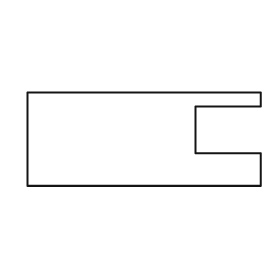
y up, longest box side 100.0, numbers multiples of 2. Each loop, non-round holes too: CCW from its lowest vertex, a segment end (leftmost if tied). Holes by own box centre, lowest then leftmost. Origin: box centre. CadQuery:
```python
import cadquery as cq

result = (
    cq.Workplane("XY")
    .moveTo(-50.0, -20.0)
    .lineTo(50.0, -20.0)
    .lineTo(50.0, -6.0)
    .lineTo(22.0, -6.0)
    .lineTo(22.0, 14.0)
    .lineTo(50.0, 14.0)
    .lineTo(50.0, 20.0)
    .lineTo(-50.0, 20.0)
    .close()
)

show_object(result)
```